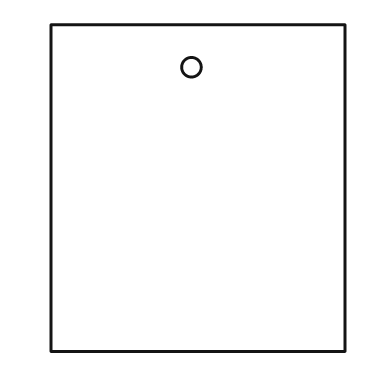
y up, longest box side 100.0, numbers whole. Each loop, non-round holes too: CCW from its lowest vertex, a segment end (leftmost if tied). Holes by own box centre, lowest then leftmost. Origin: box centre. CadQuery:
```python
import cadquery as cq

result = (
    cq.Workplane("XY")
    .moveTo(-45.0, -50.0)
    .lineTo(45.0, -50.0)
    .lineTo(45.0, 50.0)
    .lineTo(-45.0, 50.0)
    .close()
    .moveTo(-2.0, 37.0)
    .circle(3.0)
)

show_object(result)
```